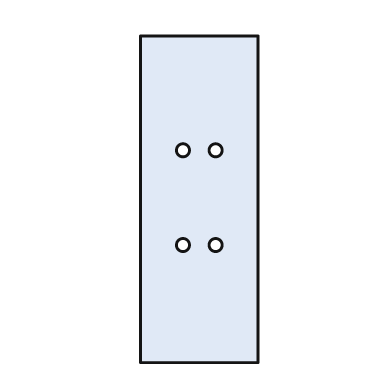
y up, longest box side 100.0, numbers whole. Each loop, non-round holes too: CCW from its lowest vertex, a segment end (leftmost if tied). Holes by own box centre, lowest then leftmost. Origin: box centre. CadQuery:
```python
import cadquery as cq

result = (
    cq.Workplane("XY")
    .moveTo(-18.0, -50.0)
    .lineTo(18.0, -50.0)
    .lineTo(18.0, 50.0)
    .lineTo(-18.0, 50.0)
    .close()
    .moveTo(-5.0, -14.0)
    .circle(2.0)
    .moveTo(5.0, -14.0)
    .circle(2.0)
    .moveTo(-5.0, 15.0)
    .circle(2.0)
    .moveTo(5.0, 15.0)
    .circle(2.0)
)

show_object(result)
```